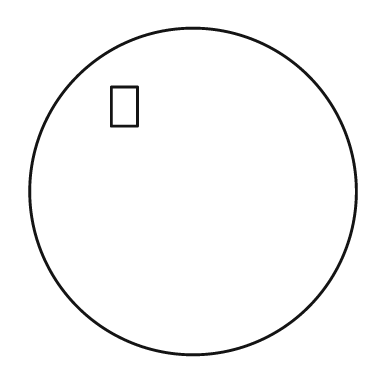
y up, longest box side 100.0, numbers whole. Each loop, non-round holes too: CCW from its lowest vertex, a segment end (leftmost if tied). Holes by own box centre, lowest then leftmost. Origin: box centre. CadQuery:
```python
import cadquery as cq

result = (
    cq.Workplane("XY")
    .moveTo(0.0, 0.0)
    .circle(50.0)
    .moveTo(-25.0, 20.0)
    .lineTo(-17.0, 20.0)
    .lineTo(-17.0, 32.0)
    .lineTo(-25.0, 32.0)
    .close()
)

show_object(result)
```